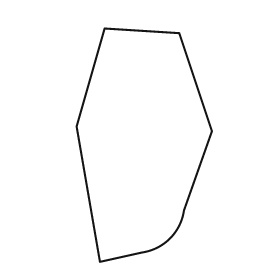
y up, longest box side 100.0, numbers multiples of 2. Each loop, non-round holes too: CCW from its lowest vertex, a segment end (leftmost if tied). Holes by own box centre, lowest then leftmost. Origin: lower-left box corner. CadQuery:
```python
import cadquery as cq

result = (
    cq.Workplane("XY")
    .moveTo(10.0, 0.0)
    .lineTo(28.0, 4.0)
    .threePointArc((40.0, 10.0), (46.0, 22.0))
    .lineTo(58.0, 56.0)
    .lineTo(44.0, 98.0)
    .lineTo(12.0, 100.0)
    .lineTo(0.0, 58.0)
    .close()
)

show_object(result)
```